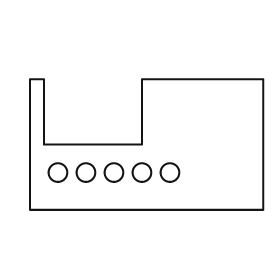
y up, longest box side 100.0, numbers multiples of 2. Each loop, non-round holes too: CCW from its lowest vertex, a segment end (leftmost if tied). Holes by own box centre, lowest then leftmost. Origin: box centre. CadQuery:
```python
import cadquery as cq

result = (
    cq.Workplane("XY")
    .moveTo(-50.0, -28.0)
    .lineTo(50.0, -28.0)
    .lineTo(50.0, 28.0)
    .lineTo(-2.0, 28.0)
    .lineTo(-2.0, 0.0)
    .lineTo(-44.0, 0.0)
    .lineTo(-44.0, 28.0)
    .lineTo(-50.0, 28.0)
    .close()
    .moveTo(-38.0, -12.0)
    .circle(4.0)
    .moveTo(-26.0, -12.0)
    .circle(4.0)
    .moveTo(-14.0, -12.0)
    .circle(4.0)
    .moveTo(-2.0, -12.0)
    .circle(4.0)
    .moveTo(10.0, -12.0)
    .circle(4.0)
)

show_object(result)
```